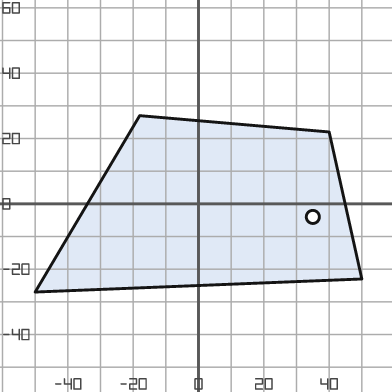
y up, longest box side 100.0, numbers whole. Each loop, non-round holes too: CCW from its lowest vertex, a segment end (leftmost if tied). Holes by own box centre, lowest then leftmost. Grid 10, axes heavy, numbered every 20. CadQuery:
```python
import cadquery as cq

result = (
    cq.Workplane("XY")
    .moveTo(-50.0, -27.0)
    .lineTo(50.0, -23.0)
    .lineTo(40.0, 22.0)
    .lineTo(-18.0, 27.0)
    .close()
    .moveTo(35.0, -4.0)
    .circle(2.0)
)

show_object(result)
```